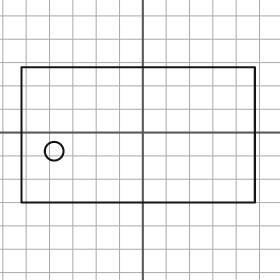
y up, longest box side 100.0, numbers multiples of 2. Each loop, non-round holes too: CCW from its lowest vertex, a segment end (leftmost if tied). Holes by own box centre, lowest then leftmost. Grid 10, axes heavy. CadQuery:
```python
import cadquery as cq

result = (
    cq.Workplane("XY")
    .moveTo(-52.0, -30.0)
    .lineTo(48.0, -30.0)
    .lineTo(48.0, 28.0)
    .lineTo(-52.0, 28.0)
    .close()
    .moveTo(-38.0, -8.0)
    .circle(4.0)
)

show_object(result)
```